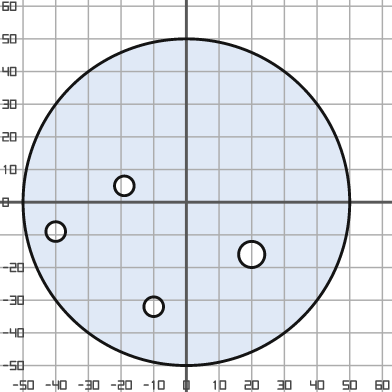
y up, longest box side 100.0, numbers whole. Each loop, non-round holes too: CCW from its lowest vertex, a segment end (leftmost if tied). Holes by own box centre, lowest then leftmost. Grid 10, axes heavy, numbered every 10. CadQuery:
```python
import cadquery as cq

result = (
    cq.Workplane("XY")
    .moveTo(0.0, 0.0)
    .circle(50.0)
    .moveTo(-10.0, -32.0)
    .circle(3.0)
    .moveTo(20.0, -16.0)
    .circle(4.0)
    .moveTo(-40.0, -9.0)
    .circle(3.0)
    .moveTo(-19.0, 5.0)
    .circle(3.0)
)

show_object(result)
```